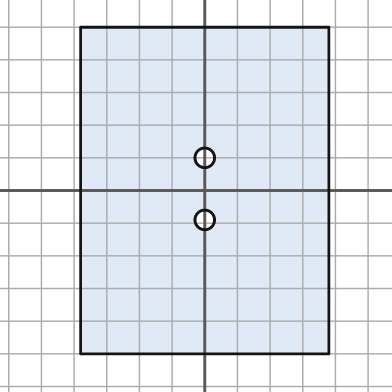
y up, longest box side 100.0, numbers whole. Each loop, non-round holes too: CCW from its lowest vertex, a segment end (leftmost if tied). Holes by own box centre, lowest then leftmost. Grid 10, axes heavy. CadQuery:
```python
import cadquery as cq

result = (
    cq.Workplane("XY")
    .moveTo(-38.0, -50.0)
    .lineTo(38.0, -50.0)
    .lineTo(38.0, 50.0)
    .lineTo(-38.0, 50.0)
    .close()
    .moveTo(0.0, -9.0)
    .circle(3.0)
    .moveTo(0.0, 10.0)
    .circle(3.0)
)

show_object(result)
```